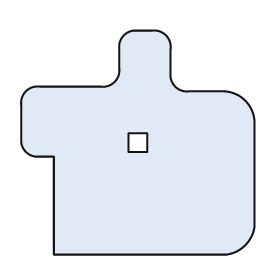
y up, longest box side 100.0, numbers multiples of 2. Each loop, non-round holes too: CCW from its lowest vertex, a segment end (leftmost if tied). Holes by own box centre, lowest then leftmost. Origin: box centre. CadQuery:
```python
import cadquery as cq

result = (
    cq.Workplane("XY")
    .moveTo(-36.0, -48.0)
    .lineTo(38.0, -48.0)
    .threePointArc((46.0, -44.0), (50.0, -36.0))
    .lineTo(50.0, 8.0)
    .threePointArc((46.0, 18.0), (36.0, 22.0))
    .lineTo(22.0, 22.0)
    .threePointArc((16.0, 24.0), (14.0, 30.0))
    .lineTo(14.0, 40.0)
    .threePointArc((12.0, 46.0), (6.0, 48.0))
    .lineTo(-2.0, 48.0)
    .threePointArc((-6.0, 46.0), (-8.0, 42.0))
    .lineTo(-8.0, 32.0)
    .threePointArc((-10.0, 26.0), (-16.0, 24.0))
    .lineTo(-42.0, 24.0)
    .threePointArc((-48.0, 22.0), (-50.0, 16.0))
    .lineTo(-50.0, 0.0)
    .threePointArc((-48.0, -4.0), (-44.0, -6.0))
    .lineTo(-36.0, -6.0)
    .close()
    .moveTo(-4.0, -4.0)
    .lineTo(4.0, -4.0)
    .lineTo(4.0, 4.0)
    .lineTo(-4.0, 4.0)
    .close()
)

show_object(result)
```